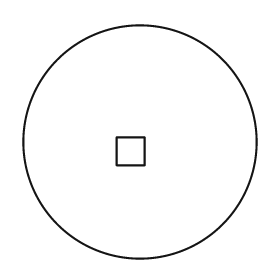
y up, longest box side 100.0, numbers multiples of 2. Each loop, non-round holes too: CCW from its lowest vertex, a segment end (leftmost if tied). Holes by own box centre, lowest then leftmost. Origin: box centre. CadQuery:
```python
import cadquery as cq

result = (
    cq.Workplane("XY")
    .moveTo(0.0, 0.0)
    .circle(50.0)
    .moveTo(-10.0, -10.0)
    .lineTo(2.0, -10.0)
    .lineTo(2.0, 2.0)
    .lineTo(-10.0, 2.0)
    .close()
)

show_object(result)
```